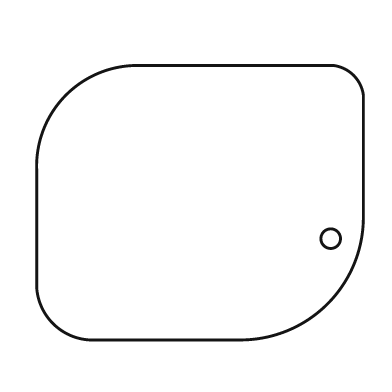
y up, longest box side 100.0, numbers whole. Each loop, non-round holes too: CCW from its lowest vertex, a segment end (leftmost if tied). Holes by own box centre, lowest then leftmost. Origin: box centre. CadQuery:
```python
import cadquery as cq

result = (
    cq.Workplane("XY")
    .moveTo(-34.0, -42.0)
    .lineTo(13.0, -42.0)
    .threePointArc((39.0, -31.0), (50.0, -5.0))
    .lineTo(50.0, 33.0)
    .threePointArc((47.0, 39.0), (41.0, 42.0))
    .lineTo(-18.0, 42.0)
    .threePointArc((-41.0, 33.0), (-50.0, 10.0))
    .lineTo(-50.0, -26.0)
    .threePointArc((-45.0, -37.0), (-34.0, -42.0))
    .close()
    .moveTo(40.0, -11.0)
    .circle(3.0)
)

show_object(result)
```